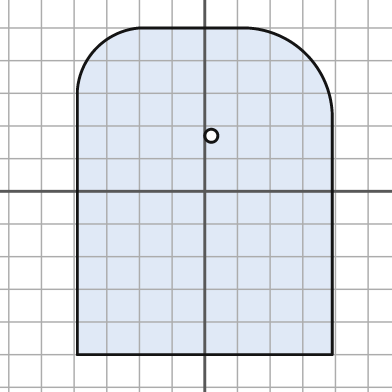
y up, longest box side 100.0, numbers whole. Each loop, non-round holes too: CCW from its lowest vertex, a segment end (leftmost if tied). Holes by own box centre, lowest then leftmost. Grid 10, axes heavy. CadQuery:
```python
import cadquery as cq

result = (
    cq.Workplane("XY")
    .moveTo(-39.0, -50.0)
    .lineTo(39.0, -50.0)
    .lineTo(39.0, 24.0)
    .threePointArc((31.0, 42.0), (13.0, 50.0))
    .lineTo(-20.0, 50.0)
    .threePointArc((-33.0, 44.0), (-39.0, 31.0))
    .close()
    .moveTo(2.0, 17.0)
    .circle(2.0)
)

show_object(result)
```